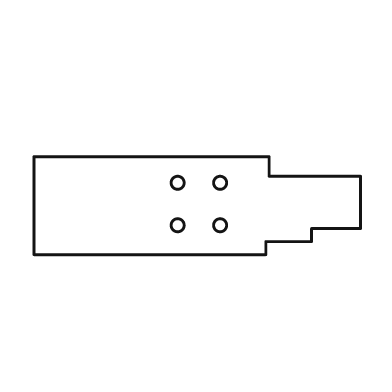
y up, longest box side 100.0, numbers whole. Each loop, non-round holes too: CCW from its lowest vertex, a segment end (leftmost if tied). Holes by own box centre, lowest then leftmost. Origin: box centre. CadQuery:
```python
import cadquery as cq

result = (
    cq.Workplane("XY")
    .moveTo(-50.0, -15.0)
    .lineTo(21.0, -15.0)
    .lineTo(21.0, -11.0)
    .lineTo(35.0, -11.0)
    .lineTo(35.0, -7.0)
    .lineTo(50.0, -7.0)
    .lineTo(50.0, 9.0)
    .lineTo(22.0, 9.0)
    .lineTo(22.0, 15.0)
    .lineTo(-50.0, 15.0)
    .close()
    .moveTo(-6.0, -6.0)
    .circle(2.0)
    .moveTo(7.0, -6.0)
    .circle(2.0)
    .moveTo(-6.0, 7.0)
    .circle(2.0)
    .moveTo(7.0, 7.0)
    .circle(2.0)
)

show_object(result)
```